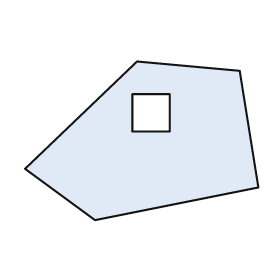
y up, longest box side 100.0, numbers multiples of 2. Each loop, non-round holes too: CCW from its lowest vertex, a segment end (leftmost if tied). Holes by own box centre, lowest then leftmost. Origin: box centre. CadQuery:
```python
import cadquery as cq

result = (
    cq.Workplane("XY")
    .moveTo(-20.0, -34.0)
    .lineTo(50.0, -20.0)
    .lineTo(42.0, 30.0)
    .lineTo(-2.0, 34.0)
    .lineTo(-50.0, -12.0)
    .close()
    .moveTo(-4.0, 4.0)
    .lineTo(12.0, 4.0)
    .lineTo(12.0, 20.0)
    .lineTo(-4.0, 20.0)
    .close()
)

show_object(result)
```